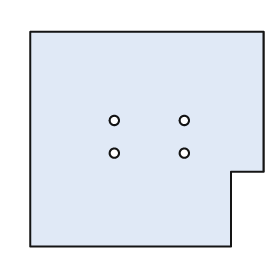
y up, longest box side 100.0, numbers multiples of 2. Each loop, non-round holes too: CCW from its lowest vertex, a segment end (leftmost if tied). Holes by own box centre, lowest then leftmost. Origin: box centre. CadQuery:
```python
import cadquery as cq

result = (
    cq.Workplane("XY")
    .moveTo(-50.0, -46.0)
    .lineTo(36.0, -46.0)
    .lineTo(36.0, -14.0)
    .lineTo(50.0, -14.0)
    .lineTo(50.0, 46.0)
    .lineTo(-50.0, 46.0)
    .close()
    .moveTo(-14.0, -6.0)
    .circle(2.0)
    .moveTo(16.0, -6.0)
    .circle(2.0)
    .moveTo(-14.0, 8.0)
    .circle(2.0)
    .moveTo(16.0, 8.0)
    .circle(2.0)
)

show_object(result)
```